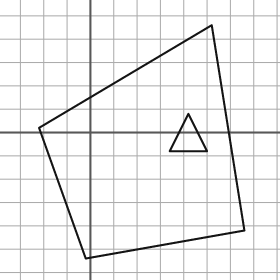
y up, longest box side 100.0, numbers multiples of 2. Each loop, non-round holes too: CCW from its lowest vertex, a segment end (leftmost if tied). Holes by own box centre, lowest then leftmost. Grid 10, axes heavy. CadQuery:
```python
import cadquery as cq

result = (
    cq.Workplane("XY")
    .moveTo(-2.0, -54.0)
    .lineTo(66.0, -42.0)
    .lineTo(52.0, 46.0)
    .lineTo(-22.0, 2.0)
    .close()
    .moveTo(34.0, -8.0)
    .lineTo(50.0, -8.0)
    .lineTo(42.0, 8.0)
    .close()
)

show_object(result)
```